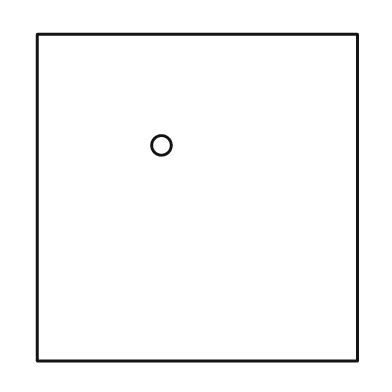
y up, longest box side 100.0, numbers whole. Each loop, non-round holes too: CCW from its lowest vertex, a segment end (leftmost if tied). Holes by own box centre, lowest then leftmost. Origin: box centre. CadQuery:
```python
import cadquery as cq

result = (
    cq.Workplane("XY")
    .moveTo(-49.0, -50.0)
    .lineTo(49.0, -50.0)
    .lineTo(49.0, 50.0)
    .lineTo(-49.0, 50.0)
    .close()
    .moveTo(-11.0, 16.0)
    .circle(3.0)
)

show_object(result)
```